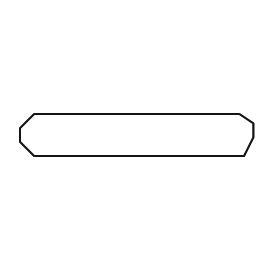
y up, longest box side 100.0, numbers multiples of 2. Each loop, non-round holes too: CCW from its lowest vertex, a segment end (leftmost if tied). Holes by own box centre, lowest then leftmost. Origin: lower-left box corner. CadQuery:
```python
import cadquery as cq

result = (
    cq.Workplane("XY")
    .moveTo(6.0, 0.0)
    .lineTo(96.0, 0.0)
    .lineTo(100.0, 8.0)
    .lineTo(100.0, 14.0)
    .lineTo(94.0, 18.0)
    .lineTo(6.0, 18.0)
    .lineTo(0.0, 12.0)
    .lineTo(0.0, 6.0)
    .close()
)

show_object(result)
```